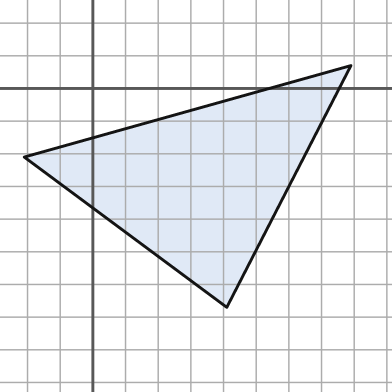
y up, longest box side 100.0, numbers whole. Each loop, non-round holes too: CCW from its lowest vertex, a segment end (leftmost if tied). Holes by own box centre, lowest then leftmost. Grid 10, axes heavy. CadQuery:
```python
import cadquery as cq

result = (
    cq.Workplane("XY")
    .moveTo(41.0, -67.0)
    .lineTo(79.0, 7.0)
    .lineTo(-21.0, -21.0)
    .close()
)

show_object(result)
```